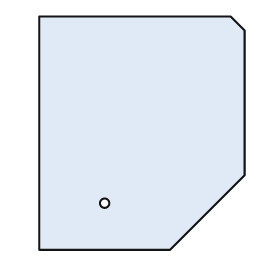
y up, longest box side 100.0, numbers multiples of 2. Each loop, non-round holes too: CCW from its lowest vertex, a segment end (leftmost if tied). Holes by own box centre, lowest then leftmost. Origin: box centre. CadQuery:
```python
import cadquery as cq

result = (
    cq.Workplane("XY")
    .moveTo(-44.0, -50.0)
    .lineTo(12.0, -50.0)
    .lineTo(44.0, -18.0)
    .lineTo(44.0, 44.0)
    .lineTo(38.0, 50.0)
    .lineTo(-44.0, 50.0)
    .close()
    .moveTo(-16.0, -30.0)
    .circle(2.0)
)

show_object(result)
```